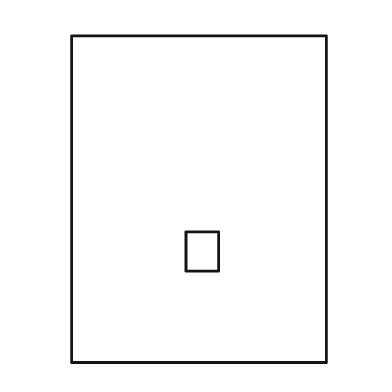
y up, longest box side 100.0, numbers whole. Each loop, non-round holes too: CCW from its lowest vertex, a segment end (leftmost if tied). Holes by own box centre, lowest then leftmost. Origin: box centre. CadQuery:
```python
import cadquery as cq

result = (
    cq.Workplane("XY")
    .moveTo(-39.0, -50.0)
    .lineTo(39.0, -50.0)
    .lineTo(39.0, 50.0)
    .lineTo(-39.0, 50.0)
    .close()
    .moveTo(-4.0, -22.0)
    .lineTo(6.0, -22.0)
    .lineTo(6.0, -10.0)
    .lineTo(-4.0, -10.0)
    .close()
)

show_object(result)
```